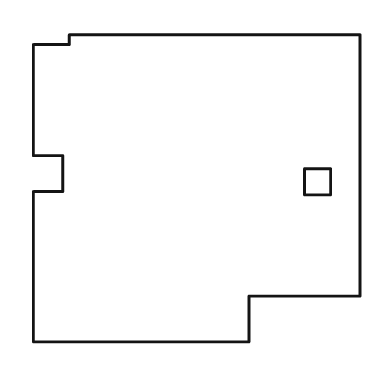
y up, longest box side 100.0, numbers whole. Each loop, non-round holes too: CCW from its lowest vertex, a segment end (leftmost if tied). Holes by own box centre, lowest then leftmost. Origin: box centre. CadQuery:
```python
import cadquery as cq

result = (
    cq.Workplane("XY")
    .moveTo(-50.0, -47.0)
    .lineTo(16.0, -47.0)
    .lineTo(16.0, -33.0)
    .lineTo(50.0, -33.0)
    .lineTo(50.0, 47.0)
    .lineTo(-39.0, 47.0)
    .lineTo(-39.0, 44.0)
    .lineTo(-50.0, 44.0)
    .lineTo(-50.0, 10.0)
    .lineTo(-41.0, 10.0)
    .lineTo(-41.0, -1.0)
    .lineTo(-50.0, -1.0)
    .close()
    .moveTo(33.0, -2.0)
    .lineTo(41.0, -2.0)
    .lineTo(41.0, 6.0)
    .lineTo(33.0, 6.0)
    .close()
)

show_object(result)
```